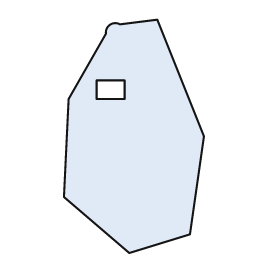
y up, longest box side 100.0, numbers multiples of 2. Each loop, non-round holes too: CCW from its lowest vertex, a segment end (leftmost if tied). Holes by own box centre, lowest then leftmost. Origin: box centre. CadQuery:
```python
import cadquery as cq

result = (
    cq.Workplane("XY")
    .moveTo(-2.0, -50.0)
    .lineTo(24.0, -42.0)
    .lineTo(30.0, 0.0)
    .lineTo(10.0, 50.0)
    .lineTo(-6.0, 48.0)
    .threePointArc((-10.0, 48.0), (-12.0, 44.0))
    .lineTo(-28.0, 16.0)
    .lineTo(-30.0, -26.0)
    .close()
    .moveTo(-16.0, 16.0)
    .lineTo(-4.0, 16.0)
    .lineTo(-4.0, 24.0)
    .lineTo(-16.0, 24.0)
    .close()
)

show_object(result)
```